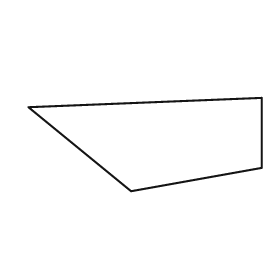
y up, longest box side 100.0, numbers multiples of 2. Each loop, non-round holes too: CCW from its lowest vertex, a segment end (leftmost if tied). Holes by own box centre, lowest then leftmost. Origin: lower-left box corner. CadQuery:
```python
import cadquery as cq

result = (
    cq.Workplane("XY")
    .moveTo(44.0, 0.0)
    .lineTo(100.0, 10.0)
    .lineTo(100.0, 40.0)
    .lineTo(0.0, 36.0)
    .close()
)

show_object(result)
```